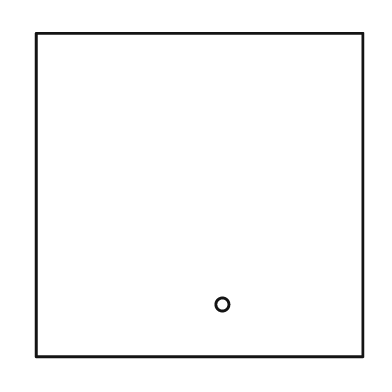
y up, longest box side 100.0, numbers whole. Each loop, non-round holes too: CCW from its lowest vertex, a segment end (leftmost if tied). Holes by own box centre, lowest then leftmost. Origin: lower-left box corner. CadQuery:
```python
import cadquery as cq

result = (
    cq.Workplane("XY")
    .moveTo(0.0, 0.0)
    .lineTo(100.0, 0.0)
    .lineTo(100.0, 99.0)
    .lineTo(0.0, 99.0)
    .close()
    .moveTo(57.0, 16.0)
    .circle(2.0)
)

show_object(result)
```